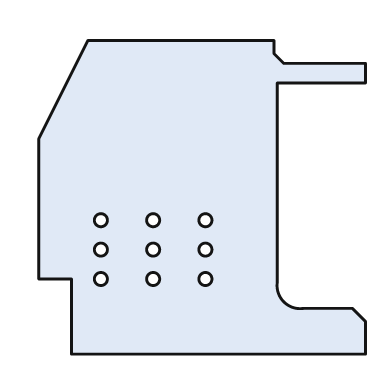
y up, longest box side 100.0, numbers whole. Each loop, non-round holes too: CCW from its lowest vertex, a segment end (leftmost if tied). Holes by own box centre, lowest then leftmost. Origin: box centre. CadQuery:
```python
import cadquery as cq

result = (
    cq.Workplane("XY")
    .moveTo(-40.0, -48.0)
    .lineTo(50.0, -48.0)
    .lineTo(50.0, -38.0)
    .lineTo(46.0, -34.0)
    .lineTo(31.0, -34.0)
    .threePointArc((25.0, -32.0), (23.0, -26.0))
    .lineTo(23.0, 35.0)
    .lineTo(50.0, 35.0)
    .lineTo(50.0, 41.0)
    .lineTo(25.0, 41.0)
    .lineTo(22.0, 44.0)
    .lineTo(22.0, 48.0)
    .lineTo(-35.0, 48.0)
    .lineTo(-50.0, 18.0)
    .lineTo(-50.0, -25.0)
    .lineTo(-40.0, -25.0)
    .close()
    .moveTo(-31.0, -25.0)
    .circle(2.0)
    .moveTo(-15.0, -25.0)
    .circle(2.0)
    .moveTo(1.0, -25.0)
    .circle(2.0)
    .moveTo(-31.0, -16.0)
    .circle(2.0)
    .moveTo(-15.0, -16.0)
    .circle(2.0)
    .moveTo(1.0, -16.0)
    .circle(2.0)
    .moveTo(-31.0, -7.0)
    .circle(2.0)
    .moveTo(-15.0, -7.0)
    .circle(2.0)
    .moveTo(1.0, -7.0)
    .circle(2.0)
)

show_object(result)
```